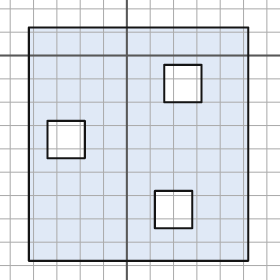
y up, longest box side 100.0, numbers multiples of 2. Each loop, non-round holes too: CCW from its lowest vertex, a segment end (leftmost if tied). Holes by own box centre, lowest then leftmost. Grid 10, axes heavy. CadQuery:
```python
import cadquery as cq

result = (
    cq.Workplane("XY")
    .moveTo(-42.0, -88.0)
    .lineTo(52.0, -88.0)
    .lineTo(52.0, 12.0)
    .lineTo(-42.0, 12.0)
    .close()
    .moveTo(12.0, -74.0)
    .lineTo(28.0, -74.0)
    .lineTo(28.0, -58.0)
    .lineTo(12.0, -58.0)
    .close()
    .moveTo(-34.0, -44.0)
    .lineTo(-18.0, -44.0)
    .lineTo(-18.0, -28.0)
    .lineTo(-34.0, -28.0)
    .close()
    .moveTo(16.0, -20.0)
    .lineTo(32.0, -20.0)
    .lineTo(32.0, -4.0)
    .lineTo(16.0, -4.0)
    .close()
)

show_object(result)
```